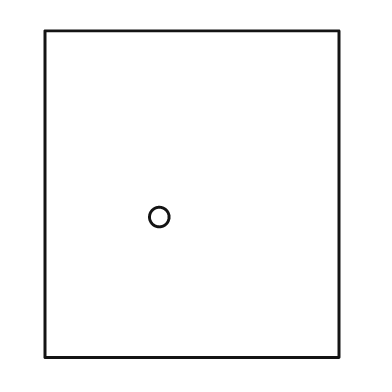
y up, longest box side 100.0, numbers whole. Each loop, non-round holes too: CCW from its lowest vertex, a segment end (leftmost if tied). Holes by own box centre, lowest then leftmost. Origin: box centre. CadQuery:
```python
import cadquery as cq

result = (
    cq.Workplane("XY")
    .moveTo(-45.0, -50.0)
    .lineTo(45.0, -50.0)
    .lineTo(45.0, 50.0)
    .lineTo(-45.0, 50.0)
    .close()
    .moveTo(-10.0, -7.0)
    .circle(3.0)
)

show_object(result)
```